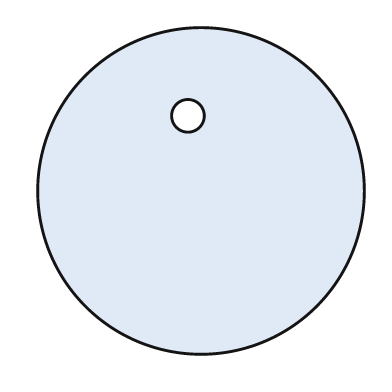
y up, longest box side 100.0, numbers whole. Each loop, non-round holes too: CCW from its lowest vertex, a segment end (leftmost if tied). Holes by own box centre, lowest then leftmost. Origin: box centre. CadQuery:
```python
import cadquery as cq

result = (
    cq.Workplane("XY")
    .moveTo(0.0, 0.0)
    .circle(50.0)
    .moveTo(-4.0, 23.0)
    .circle(5.0)
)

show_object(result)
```